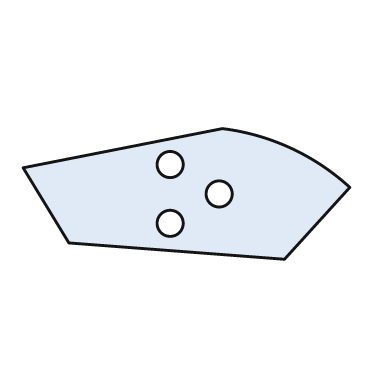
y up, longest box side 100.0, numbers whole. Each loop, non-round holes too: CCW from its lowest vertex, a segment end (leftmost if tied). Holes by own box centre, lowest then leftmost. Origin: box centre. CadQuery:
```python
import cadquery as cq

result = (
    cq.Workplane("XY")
    .moveTo(30.0, -20.0)
    .lineTo(50.0, 2.0)
    .threePointArc((32.0, 14.0), (11.0, 20.0))
    .lineTo(-50.0, 8.0)
    .lineTo(-36.0, -15.0)
    .close()
    .moveTo(-5.0, -9.0)
    .circle(4.0)
    .moveTo(10.0, 0.0)
    .circle(4.0)
    .moveTo(-5.0, 9.0)
    .circle(4.0)
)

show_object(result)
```